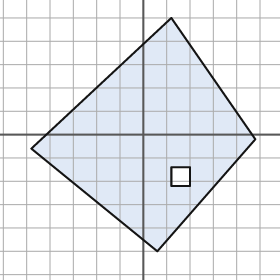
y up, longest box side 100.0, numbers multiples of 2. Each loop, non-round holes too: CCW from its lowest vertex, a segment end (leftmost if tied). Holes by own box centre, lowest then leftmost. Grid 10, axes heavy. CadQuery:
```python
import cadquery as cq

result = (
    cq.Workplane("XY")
    .moveTo(6.0, -50.0)
    .lineTo(48.0, -2.0)
    .lineTo(12.0, 50.0)
    .lineTo(-48.0, -6.0)
    .close()
    .moveTo(12.0, -22.0)
    .lineTo(20.0, -22.0)
    .lineTo(20.0, -14.0)
    .lineTo(12.0, -14.0)
    .close()
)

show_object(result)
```